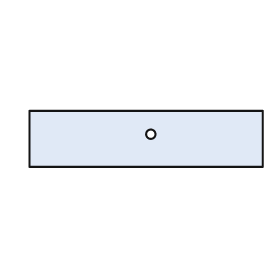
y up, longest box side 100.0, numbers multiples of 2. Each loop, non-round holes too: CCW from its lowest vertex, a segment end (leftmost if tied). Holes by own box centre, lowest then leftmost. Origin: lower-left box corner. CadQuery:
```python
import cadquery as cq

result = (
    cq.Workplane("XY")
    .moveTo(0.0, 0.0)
    .lineTo(100.0, 0.0)
    .lineTo(100.0, 24.0)
    .lineTo(0.0, 24.0)
    .close()
    .moveTo(52.0, 14.0)
    .circle(2.0)
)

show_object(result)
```